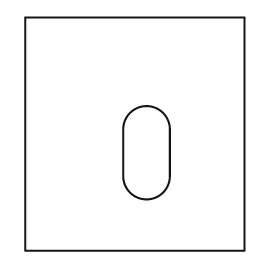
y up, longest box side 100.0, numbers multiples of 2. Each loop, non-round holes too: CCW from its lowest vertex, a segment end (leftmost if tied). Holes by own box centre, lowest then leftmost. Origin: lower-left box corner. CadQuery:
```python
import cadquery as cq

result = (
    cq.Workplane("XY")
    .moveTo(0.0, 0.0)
    .lineTo(94.0, 0.0)
    .lineTo(94.0, 100.0)
    .lineTo(0.0, 100.0)
    .close()
    .moveTo(42.0, 32.0)
    .threePointArc((52.0, 22.0), (62.0, 32.0))
    .lineTo(62.0, 52.0)
    .threePointArc((52.0, 62.0), (42.0, 52.0))
    .close()
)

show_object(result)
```